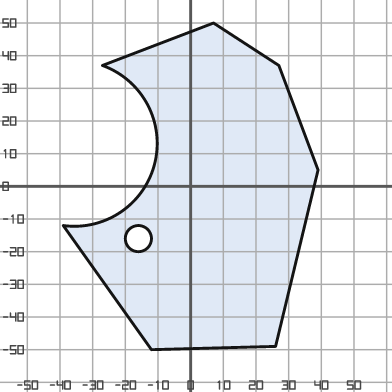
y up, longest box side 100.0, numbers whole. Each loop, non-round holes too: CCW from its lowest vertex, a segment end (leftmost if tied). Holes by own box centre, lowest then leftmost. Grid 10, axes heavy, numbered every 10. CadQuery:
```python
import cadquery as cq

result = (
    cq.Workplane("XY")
    .moveTo(-12.0, -50.0)
    .lineTo(26.0, -49.0)
    .lineTo(39.0, 5.0)
    .lineTo(27.0, 37.0)
    .lineTo(7.0, 50.0)
    .lineTo(-27.0, 37.0)
    .threePointArc((-11.0, 7.0), (-39.0, -12.0))
    .close()
    .moveTo(-16.0, -16.0)
    .circle(4.0)
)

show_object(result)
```